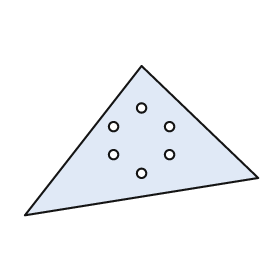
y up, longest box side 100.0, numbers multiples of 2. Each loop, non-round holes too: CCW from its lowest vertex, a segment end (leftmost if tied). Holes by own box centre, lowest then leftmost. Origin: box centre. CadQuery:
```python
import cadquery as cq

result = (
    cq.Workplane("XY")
    .moveTo(-50.0, -32.0)
    .lineTo(50.0, -16.0)
    .lineTo(0.0, 32.0)
    .close()
    .moveTo(0.0, -14.0)
    .circle(2.0)
    .moveTo(-12.0, -6.0)
    .circle(2.0)
    .moveTo(12.0, -6.0)
    .circle(2.0)
    .moveTo(-12.0, 6.0)
    .circle(2.0)
    .moveTo(12.0, 6.0)
    .circle(2.0)
    .moveTo(0.0, 14.0)
    .circle(2.0)
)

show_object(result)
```